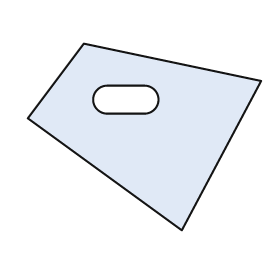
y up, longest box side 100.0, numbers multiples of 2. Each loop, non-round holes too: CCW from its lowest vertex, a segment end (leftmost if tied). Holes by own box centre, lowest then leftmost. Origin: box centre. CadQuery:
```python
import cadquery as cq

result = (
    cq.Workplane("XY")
    .moveTo(16.0, -40.0)
    .lineTo(50.0, 24.0)
    .lineTo(-26.0, 40.0)
    .lineTo(-50.0, 8.0)
    .close()
    .moveTo(-16.0, 10.0)
    .lineTo(0.0, 10.0)
    .threePointArc((6.0, 16.0), (0.0, 22.0))
    .lineTo(-16.0, 22.0)
    .threePointArc((-22.0, 16.0), (-16.0, 10.0))
    .close()
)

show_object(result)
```